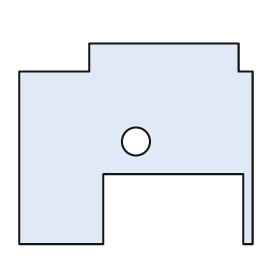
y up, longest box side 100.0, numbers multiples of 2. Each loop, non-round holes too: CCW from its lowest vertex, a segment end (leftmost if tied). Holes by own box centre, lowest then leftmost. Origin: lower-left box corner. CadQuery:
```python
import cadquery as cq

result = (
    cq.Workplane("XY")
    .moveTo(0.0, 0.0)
    .lineTo(36.0, 0.0)
    .lineTo(36.0, 30.0)
    .lineTo(96.0, 30.0)
    .lineTo(96.0, 0.0)
    .lineTo(100.0, 0.0)
    .lineTo(100.0, 74.0)
    .lineTo(94.0, 74.0)
    .lineTo(94.0, 86.0)
    .lineTo(30.0, 86.0)
    .lineTo(30.0, 74.0)
    .lineTo(0.0, 74.0)
    .close()
    .moveTo(50.0, 44.0)
    .circle(6.0)
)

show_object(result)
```